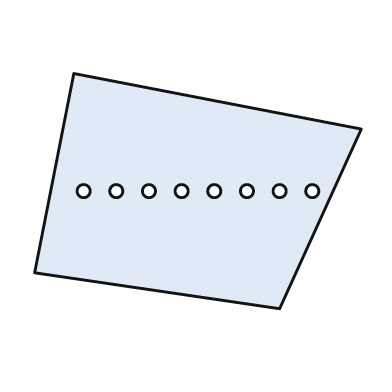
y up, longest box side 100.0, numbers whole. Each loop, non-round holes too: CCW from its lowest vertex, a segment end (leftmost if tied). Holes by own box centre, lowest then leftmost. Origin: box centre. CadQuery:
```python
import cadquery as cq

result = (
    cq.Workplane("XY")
    .moveTo(25.0, -36.0)
    .lineTo(50.0, 19.0)
    .lineTo(-38.0, 36.0)
    .lineTo(-50.0, -25.0)
    .close()
    .moveTo(-35.0, 0.0)
    .circle(2.0)
    .moveTo(-25.0, 0.0)
    .circle(2.0)
    .moveTo(-15.0, 0.0)
    .circle(2.0)
    .moveTo(-5.0, 0.0)
    .circle(2.0)
    .moveTo(5.0, 0.0)
    .circle(2.0)
    .moveTo(15.0, 0.0)
    .circle(2.0)
    .moveTo(25.0, 0.0)
    .circle(2.0)
    .moveTo(35.0, 0.0)
    .circle(2.0)
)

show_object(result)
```